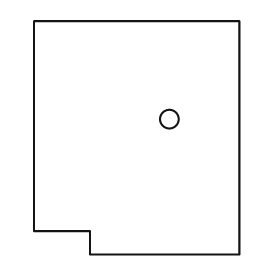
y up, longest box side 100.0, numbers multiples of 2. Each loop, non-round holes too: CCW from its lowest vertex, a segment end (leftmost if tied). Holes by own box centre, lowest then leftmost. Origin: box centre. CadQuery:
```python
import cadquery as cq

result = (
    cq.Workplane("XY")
    .moveTo(-20.0, -50.0)
    .lineTo(44.0, -50.0)
    .lineTo(44.0, 50.0)
    .lineTo(-44.0, 50.0)
    .lineTo(-44.0, -40.0)
    .lineTo(-20.0, -40.0)
    .close()
    .moveTo(14.0, 8.0)
    .circle(4.0)
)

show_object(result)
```